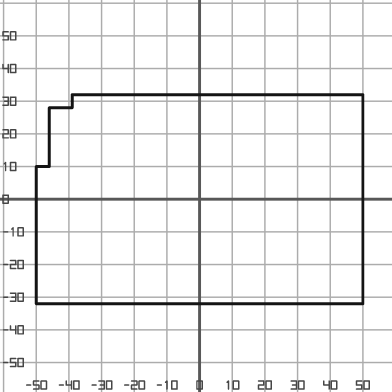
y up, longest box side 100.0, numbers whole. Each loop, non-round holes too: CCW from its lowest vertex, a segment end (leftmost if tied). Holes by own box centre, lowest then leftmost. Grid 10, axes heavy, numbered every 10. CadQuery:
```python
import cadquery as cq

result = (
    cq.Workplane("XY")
    .moveTo(-50.0, -32.0)
    .lineTo(50.0, -32.0)
    .lineTo(50.0, 32.0)
    .lineTo(-39.0, 32.0)
    .lineTo(-39.0, 28.0)
    .lineTo(-46.0, 28.0)
    .lineTo(-46.0, 10.0)
    .lineTo(-50.0, 10.0)
    .close()
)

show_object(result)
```